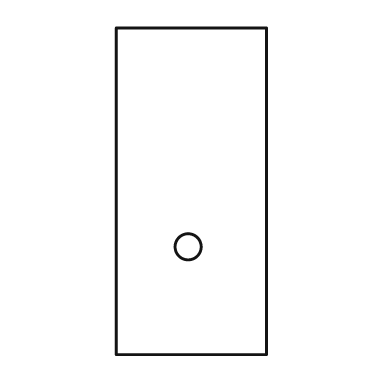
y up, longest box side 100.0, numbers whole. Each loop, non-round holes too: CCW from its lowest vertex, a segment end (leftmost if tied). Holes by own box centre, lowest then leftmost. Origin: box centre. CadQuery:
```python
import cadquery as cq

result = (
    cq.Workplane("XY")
    .moveTo(-23.0, -50.0)
    .lineTo(23.0, -50.0)
    .lineTo(23.0, 50.0)
    .lineTo(-23.0, 50.0)
    .close()
    .moveTo(-1.0, -17.0)
    .circle(4.0)
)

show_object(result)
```